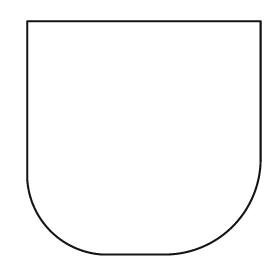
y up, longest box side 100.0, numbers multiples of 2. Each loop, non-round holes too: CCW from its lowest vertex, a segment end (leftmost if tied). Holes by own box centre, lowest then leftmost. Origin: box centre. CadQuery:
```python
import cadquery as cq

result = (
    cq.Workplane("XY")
    .moveTo(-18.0, -50.0)
    .lineTo(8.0, -50.0)
    .threePointArc((38.0, -38.0), (50.0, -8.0))
    .lineTo(50.0, 50.0)
    .lineTo(-50.0, 50.0)
    .lineTo(-50.0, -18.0)
    .threePointArc((-40.0, -40.0), (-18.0, -50.0))
    .close()
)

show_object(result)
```